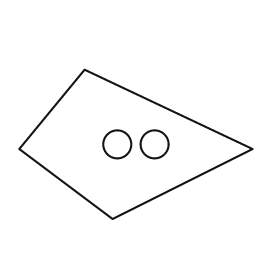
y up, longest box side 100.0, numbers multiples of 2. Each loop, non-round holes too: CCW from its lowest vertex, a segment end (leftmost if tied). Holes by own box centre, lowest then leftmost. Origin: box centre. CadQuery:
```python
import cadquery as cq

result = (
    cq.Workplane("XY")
    .moveTo(-10.0, -32.0)
    .lineTo(50.0, -2.0)
    .lineTo(-22.0, 32.0)
    .lineTo(-50.0, -2.0)
    .close()
    .moveTo(-8.0, 0.0)
    .circle(6.0)
    .moveTo(8.0, 0.0)
    .circle(6.0)
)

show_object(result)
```